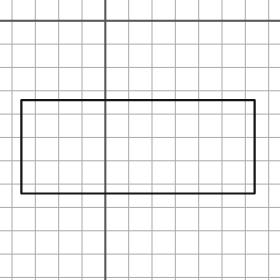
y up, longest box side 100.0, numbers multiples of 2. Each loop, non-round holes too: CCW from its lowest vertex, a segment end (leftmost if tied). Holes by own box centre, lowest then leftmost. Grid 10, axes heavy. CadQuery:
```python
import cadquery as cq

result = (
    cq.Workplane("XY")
    .moveTo(-36.0, -74.0)
    .lineTo(64.0, -74.0)
    .lineTo(64.0, -34.0)
    .lineTo(-36.0, -34.0)
    .close()
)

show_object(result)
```